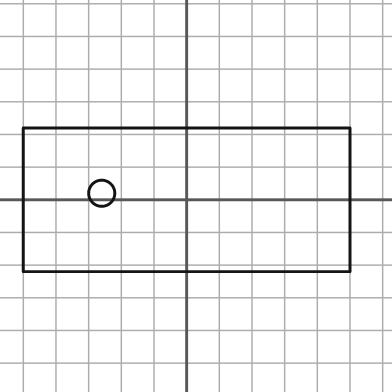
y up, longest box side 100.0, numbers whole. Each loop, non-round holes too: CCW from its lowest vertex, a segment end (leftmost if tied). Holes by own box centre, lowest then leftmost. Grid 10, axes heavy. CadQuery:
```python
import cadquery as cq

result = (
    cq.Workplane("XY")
    .moveTo(-50.0, -22.0)
    .lineTo(50.0, -22.0)
    .lineTo(50.0, 22.0)
    .lineTo(-50.0, 22.0)
    .close()
    .moveTo(-26.0, 2.0)
    .circle(4.0)
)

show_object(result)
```